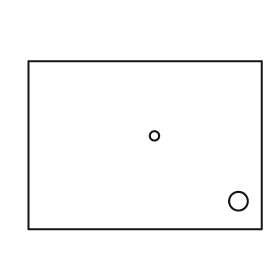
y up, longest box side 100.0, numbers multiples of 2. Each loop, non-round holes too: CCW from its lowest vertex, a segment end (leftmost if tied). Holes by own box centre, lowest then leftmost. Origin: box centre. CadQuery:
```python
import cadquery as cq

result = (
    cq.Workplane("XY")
    .moveTo(-50.0, -36.0)
    .lineTo(50.0, -36.0)
    .lineTo(50.0, 36.0)
    .lineTo(-50.0, 36.0)
    .close()
    .moveTo(40.0, -24.0)
    .circle(4.0)
    .moveTo(4.0, 4.0)
    .circle(2.0)
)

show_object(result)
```